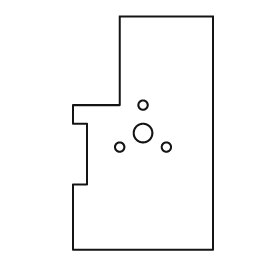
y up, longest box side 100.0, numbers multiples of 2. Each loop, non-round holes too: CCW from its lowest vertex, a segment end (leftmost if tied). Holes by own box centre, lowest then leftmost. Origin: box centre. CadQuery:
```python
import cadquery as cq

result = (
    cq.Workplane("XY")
    .moveTo(-30.0, -50.0)
    .lineTo(30.0, -50.0)
    .lineTo(30.0, 50.0)
    .lineTo(-10.0, 50.0)
    .lineTo(-10.0, 12.0)
    .lineTo(-30.0, 12.0)
    .lineTo(-30.0, 4.0)
    .lineTo(-24.0, 4.0)
    .lineTo(-24.0, -22.0)
    .lineTo(-30.0, -22.0)
    .close()
    .moveTo(-10.0, -6.0)
    .circle(2.0)
    .moveTo(10.0, -6.0)
    .circle(2.0)
    .moveTo(0.0, 0.0)
    .circle(4.0)
    .moveTo(0.0, 12.0)
    .circle(2.0)
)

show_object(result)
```